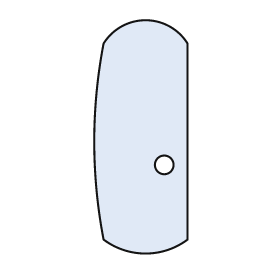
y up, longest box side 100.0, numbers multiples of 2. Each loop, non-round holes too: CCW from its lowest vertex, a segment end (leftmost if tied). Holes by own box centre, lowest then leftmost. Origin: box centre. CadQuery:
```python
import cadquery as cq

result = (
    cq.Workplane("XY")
    .moveTo(-16.0, -44.0)
    .threePointArc((2.0, -50.0), (20.0, -44.0))
    .lineTo(20.0, 40.0)
    .threePointArc((2.0, 50.0), (-16.0, 40.0))
    .threePointArc((-20.0, -2.0), (-16.0, -44.0))
    .close()
    .moveTo(10.0, -12.0)
    .circle(4.0)
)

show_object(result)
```